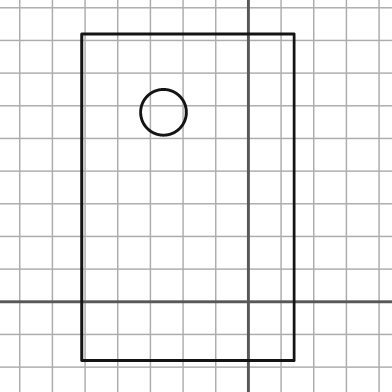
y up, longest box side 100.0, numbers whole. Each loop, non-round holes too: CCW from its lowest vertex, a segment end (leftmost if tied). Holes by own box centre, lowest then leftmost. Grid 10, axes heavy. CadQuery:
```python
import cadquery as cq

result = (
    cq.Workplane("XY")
    .moveTo(-51.0, -18.0)
    .lineTo(14.0, -18.0)
    .lineTo(14.0, 82.0)
    .lineTo(-51.0, 82.0)
    .close()
    .moveTo(-26.0, 58.0)
    .circle(7.0)
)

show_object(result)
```